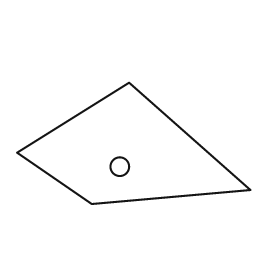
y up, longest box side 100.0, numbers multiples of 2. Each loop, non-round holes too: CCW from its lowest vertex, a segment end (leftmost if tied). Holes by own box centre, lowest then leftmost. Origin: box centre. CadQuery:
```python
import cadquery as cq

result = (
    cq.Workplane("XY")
    .moveTo(-18.0, -26.0)
    .lineTo(50.0, -20.0)
    .lineTo(-2.0, 26.0)
    .lineTo(-50.0, -4.0)
    .close()
    .moveTo(-6.0, -10.0)
    .circle(4.0)
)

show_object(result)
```